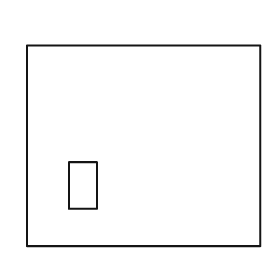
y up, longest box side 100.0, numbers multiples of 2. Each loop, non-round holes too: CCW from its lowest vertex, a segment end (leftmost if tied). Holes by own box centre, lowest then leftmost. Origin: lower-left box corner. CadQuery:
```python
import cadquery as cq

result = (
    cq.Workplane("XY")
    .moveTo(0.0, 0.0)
    .lineTo(100.0, 0.0)
    .lineTo(100.0, 86.0)
    .lineTo(0.0, 86.0)
    .close()
    .moveTo(18.0, 16.0)
    .lineTo(30.0, 16.0)
    .lineTo(30.0, 36.0)
    .lineTo(18.0, 36.0)
    .close()
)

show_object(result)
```